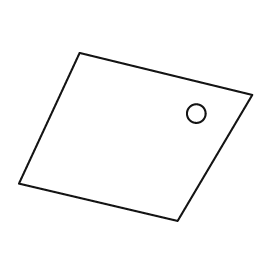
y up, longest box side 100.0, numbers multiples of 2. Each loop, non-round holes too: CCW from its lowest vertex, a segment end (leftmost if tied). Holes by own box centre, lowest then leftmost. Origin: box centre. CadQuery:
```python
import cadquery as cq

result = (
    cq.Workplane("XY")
    .moveTo(18.0, -36.0)
    .lineTo(50.0, 18.0)
    .lineTo(-24.0, 36.0)
    .lineTo(-50.0, -20.0)
    .close()
    .moveTo(26.0, 10.0)
    .circle(4.0)
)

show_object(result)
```